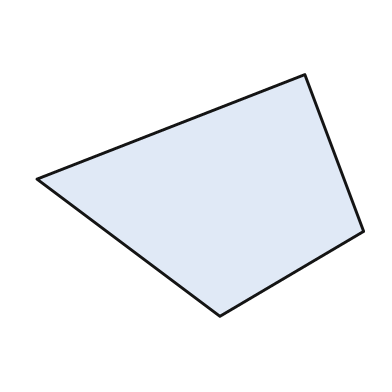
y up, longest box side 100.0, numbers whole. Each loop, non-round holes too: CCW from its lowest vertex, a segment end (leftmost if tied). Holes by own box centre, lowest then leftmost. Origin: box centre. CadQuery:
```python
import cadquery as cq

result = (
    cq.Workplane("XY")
    .moveTo(6.0, -37.0)
    .lineTo(50.0, -11.0)
    .lineTo(32.0, 37.0)
    .lineTo(-50.0, 5.0)
    .close()
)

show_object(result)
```